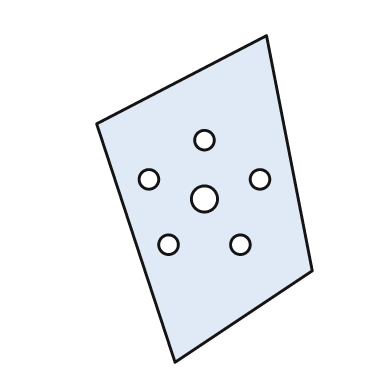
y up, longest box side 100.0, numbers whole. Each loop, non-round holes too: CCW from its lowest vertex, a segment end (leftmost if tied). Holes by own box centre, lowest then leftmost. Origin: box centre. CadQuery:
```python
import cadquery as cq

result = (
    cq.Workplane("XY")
    .moveTo(-9.0, -50.0)
    .lineTo(33.0, -22.0)
    .lineTo(19.0, 50.0)
    .lineTo(-33.0, 23.0)
    .close()
    .moveTo(-11.0, -14.0)
    .circle(3.0)
    .moveTo(11.0, -14.0)
    .circle(3.0)
    .moveTo(0.0, 0.0)
    .circle(4.0)
    .moveTo(-17.0, 6.0)
    .circle(3.0)
    .moveTo(17.0, 6.0)
    .circle(3.0)
    .moveTo(0.0, 18.0)
    .circle(3.0)
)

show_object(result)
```